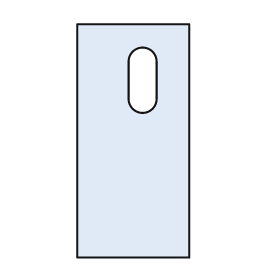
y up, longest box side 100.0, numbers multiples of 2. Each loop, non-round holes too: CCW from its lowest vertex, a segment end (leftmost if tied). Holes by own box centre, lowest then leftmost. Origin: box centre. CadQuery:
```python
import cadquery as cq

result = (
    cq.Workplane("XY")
    .moveTo(-24.0, -50.0)
    .lineTo(24.0, -50.0)
    .lineTo(24.0, 50.0)
    .lineTo(-24.0, 50.0)
    .close()
    .moveTo(-2.0, 18.0)
    .threePointArc((4.0, 12.0), (10.0, 18.0))
    .lineTo(10.0, 34.0)
    .threePointArc((4.0, 40.0), (-2.0, 34.0))
    .close()
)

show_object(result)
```